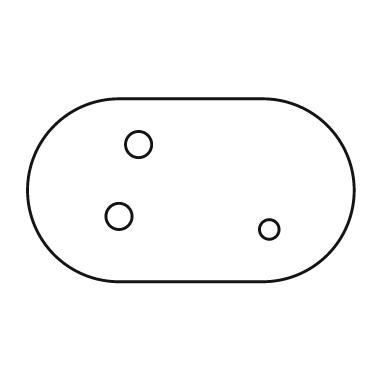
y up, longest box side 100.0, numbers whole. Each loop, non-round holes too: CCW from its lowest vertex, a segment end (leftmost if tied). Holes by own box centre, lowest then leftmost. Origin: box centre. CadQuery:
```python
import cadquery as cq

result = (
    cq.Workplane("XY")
    .moveTo(-22.0, -28.0)
    .lineTo(22.0, -28.0)
    .threePointArc((50.0, 0.0), (22.0, 28.0))
    .lineTo(-22.0, 28.0)
    .threePointArc((-50.0, 0.0), (-22.0, -28.0))
    .close()
    .moveTo(24.0, -12.0)
    .circle(3.0)
    .moveTo(-22.0, -8.0)
    .circle(4.0)
    .moveTo(-16.0, 14.0)
    .circle(4.0)
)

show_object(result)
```